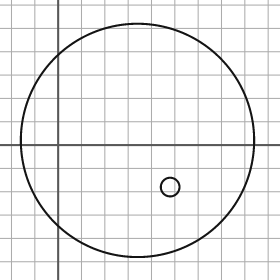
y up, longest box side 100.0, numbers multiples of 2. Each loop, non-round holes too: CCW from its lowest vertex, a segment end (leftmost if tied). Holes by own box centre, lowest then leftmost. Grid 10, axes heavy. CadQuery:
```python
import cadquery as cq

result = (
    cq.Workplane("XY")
    .moveTo(34.0, 2.0)
    .circle(50.0)
    .moveTo(48.0, -18.0)
    .circle(4.0)
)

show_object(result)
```